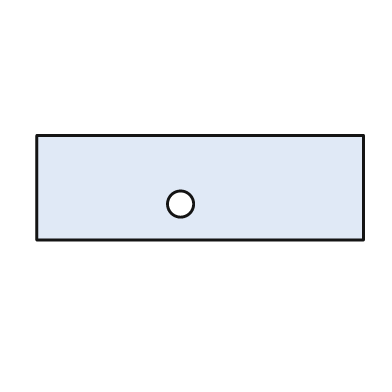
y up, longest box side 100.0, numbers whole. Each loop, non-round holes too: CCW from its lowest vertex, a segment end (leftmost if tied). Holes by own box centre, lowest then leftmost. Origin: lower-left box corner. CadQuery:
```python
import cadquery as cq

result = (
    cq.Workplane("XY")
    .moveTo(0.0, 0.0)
    .lineTo(100.0, 0.0)
    .lineTo(100.0, 32.0)
    .lineTo(0.0, 32.0)
    .close()
    .moveTo(44.0, 11.0)
    .circle(4.0)
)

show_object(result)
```